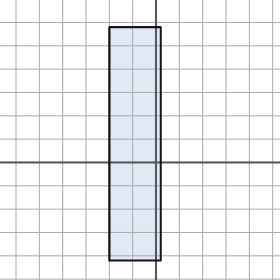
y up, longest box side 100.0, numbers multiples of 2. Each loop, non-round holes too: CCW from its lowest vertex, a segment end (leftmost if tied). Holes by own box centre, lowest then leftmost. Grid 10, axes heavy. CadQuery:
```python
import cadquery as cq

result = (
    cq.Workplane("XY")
    .moveTo(-20.0, -42.0)
    .lineTo(2.0, -42.0)
    .lineTo(2.0, 58.0)
    .lineTo(-20.0, 58.0)
    .close()
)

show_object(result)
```